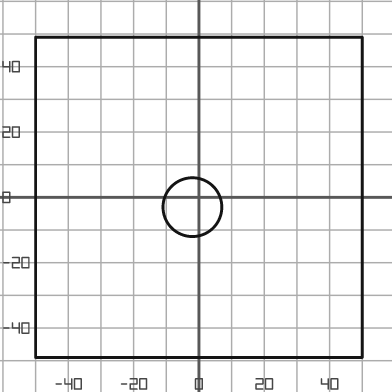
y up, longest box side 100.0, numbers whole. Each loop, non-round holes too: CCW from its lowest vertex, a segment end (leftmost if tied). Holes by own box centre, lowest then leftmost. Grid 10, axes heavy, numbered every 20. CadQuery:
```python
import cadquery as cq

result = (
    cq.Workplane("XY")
    .moveTo(-50.0, -49.0)
    .lineTo(50.0, -49.0)
    .lineTo(50.0, 49.0)
    .lineTo(-50.0, 49.0)
    .close()
    .moveTo(-2.0, -3.0)
    .circle(9.0)
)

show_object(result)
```